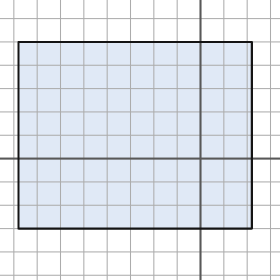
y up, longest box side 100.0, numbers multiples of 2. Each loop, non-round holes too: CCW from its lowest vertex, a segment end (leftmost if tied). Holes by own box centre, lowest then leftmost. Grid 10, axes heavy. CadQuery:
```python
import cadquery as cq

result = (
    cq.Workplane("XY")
    .moveTo(-78.0, -30.0)
    .lineTo(22.0, -30.0)
    .lineTo(22.0, 50.0)
    .lineTo(-78.0, 50.0)
    .close()
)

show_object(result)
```